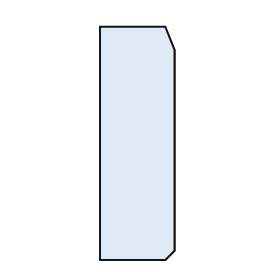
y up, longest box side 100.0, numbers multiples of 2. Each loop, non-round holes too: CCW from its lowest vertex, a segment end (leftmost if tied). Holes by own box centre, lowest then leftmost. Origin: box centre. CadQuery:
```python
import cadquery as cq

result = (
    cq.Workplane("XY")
    .moveTo(-16.0, -50.0)
    .lineTo(12.0, -50.0)
    .lineTo(16.0, -46.0)
    .lineTo(16.0, 40.0)
    .lineTo(12.0, 50.0)
    .lineTo(-16.0, 50.0)
    .close()
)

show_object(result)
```